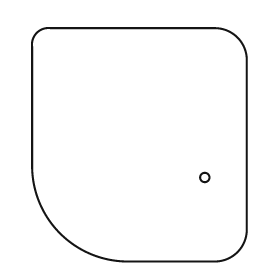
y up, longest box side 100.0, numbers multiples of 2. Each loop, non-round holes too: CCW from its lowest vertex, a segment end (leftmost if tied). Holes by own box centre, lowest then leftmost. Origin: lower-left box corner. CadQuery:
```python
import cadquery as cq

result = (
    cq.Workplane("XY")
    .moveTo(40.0, 0.0)
    .lineTo(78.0, 0.0)
    .threePointArc((88.0, 4.0), (92.0, 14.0))
    .lineTo(92.0, 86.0)
    .threePointArc((88.0, 96.0), (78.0, 100.0))
    .lineTo(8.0, 100.0)
    .threePointArc((2.0, 98.0), (0.0, 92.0))
    .lineTo(0.0, 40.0)
    .threePointArc((12.0, 12.0), (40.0, 0.0))
    .close()
    .moveTo(74.0, 36.0)
    .circle(2.0)
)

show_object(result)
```